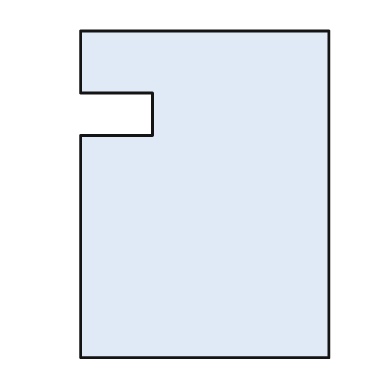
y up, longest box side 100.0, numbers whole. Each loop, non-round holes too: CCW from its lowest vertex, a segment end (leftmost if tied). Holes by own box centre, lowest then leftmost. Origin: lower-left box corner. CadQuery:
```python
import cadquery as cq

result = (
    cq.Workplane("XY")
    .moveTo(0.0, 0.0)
    .lineTo(76.0, 0.0)
    .lineTo(76.0, 100.0)
    .lineTo(0.0, 100.0)
    .lineTo(0.0, 81.0)
    .lineTo(22.0, 81.0)
    .lineTo(22.0, 68.0)
    .lineTo(0.0, 68.0)
    .close()
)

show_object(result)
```